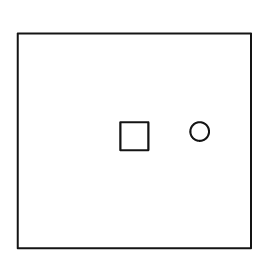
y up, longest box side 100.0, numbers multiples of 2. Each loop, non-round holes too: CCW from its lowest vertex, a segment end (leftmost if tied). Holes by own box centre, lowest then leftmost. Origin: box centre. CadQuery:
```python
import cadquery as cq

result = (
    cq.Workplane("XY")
    .moveTo(-50.0, -46.0)
    .lineTo(50.0, -46.0)
    .lineTo(50.0, 46.0)
    .lineTo(-50.0, 46.0)
    .close()
    .moveTo(-6.0, -4.0)
    .lineTo(6.0, -4.0)
    .lineTo(6.0, 8.0)
    .lineTo(-6.0, 8.0)
    .close()
    .moveTo(28.0, 4.0)
    .circle(4.0)
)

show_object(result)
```